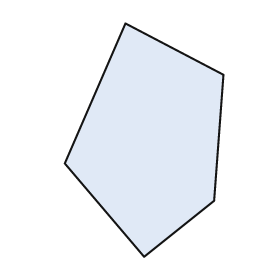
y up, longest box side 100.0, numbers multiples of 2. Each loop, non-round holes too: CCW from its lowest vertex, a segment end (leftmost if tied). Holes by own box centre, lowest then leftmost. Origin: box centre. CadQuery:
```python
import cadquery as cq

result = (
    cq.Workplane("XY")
    .moveTo(0.0, -50.0)
    .lineTo(30.0, -26.0)
    .lineTo(34.0, 28.0)
    .lineTo(-8.0, 50.0)
    .lineTo(-34.0, -10.0)
    .close()
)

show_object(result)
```